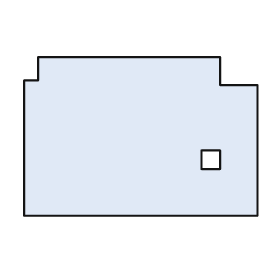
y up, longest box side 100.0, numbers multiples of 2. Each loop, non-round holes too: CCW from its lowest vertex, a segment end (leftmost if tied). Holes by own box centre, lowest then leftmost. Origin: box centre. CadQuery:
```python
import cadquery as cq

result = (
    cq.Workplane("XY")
    .moveTo(-50.0, -34.0)
    .lineTo(50.0, -34.0)
    .lineTo(50.0, 22.0)
    .lineTo(34.0, 22.0)
    .lineTo(34.0, 34.0)
    .lineTo(-44.0, 34.0)
    .lineTo(-44.0, 24.0)
    .lineTo(-50.0, 24.0)
    .close()
    .moveTo(26.0, -14.0)
    .lineTo(34.0, -14.0)
    .lineTo(34.0, -6.0)
    .lineTo(26.0, -6.0)
    .close()
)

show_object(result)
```